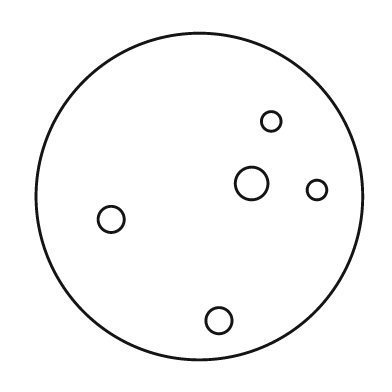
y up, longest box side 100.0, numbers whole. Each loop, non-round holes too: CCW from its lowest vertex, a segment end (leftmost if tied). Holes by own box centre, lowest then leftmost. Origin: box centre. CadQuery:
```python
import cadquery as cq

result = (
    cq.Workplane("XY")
    .moveTo(0.0, 0.0)
    .circle(50.0)
    .moveTo(6.0, -38.0)
    .circle(4.0)
    .moveTo(-27.0, -7.0)
    .circle(4.0)
    .moveTo(36.0, 2.0)
    .circle(3.0)
    .moveTo(16.0, 4.0)
    .circle(5.0)
    .moveTo(22.0, 23.0)
    .circle(3.0)
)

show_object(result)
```